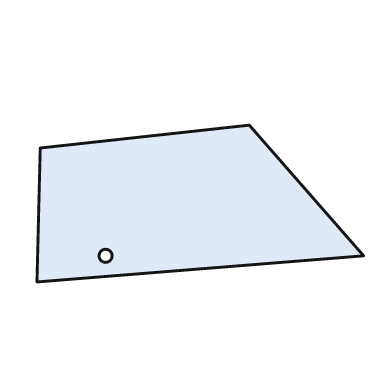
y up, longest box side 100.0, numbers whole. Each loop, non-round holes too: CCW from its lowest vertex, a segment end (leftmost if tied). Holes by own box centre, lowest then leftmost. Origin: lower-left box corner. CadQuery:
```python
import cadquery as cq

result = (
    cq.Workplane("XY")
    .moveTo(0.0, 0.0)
    .lineTo(100.0, 8.0)
    .lineTo(65.0, 48.0)
    .lineTo(1.0, 41.0)
    .close()
    .moveTo(21.0, 8.0)
    .circle(2.0)
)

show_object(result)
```